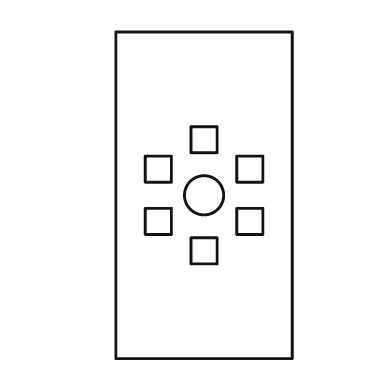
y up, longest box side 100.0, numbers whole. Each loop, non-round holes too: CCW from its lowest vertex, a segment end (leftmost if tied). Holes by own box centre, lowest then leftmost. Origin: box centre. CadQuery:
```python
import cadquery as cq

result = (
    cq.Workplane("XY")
    .moveTo(-27.0, -50.0)
    .lineTo(27.0, -50.0)
    .lineTo(27.0, 50.0)
    .lineTo(-27.0, 50.0)
    .close()
    .moveTo(-4.0, -21.0)
    .lineTo(4.0, -21.0)
    .lineTo(4.0, -13.0)
    .lineTo(-4.0, -13.0)
    .close()
    .moveTo(-18.0, -12.0)
    .lineTo(-10.0, -12.0)
    .lineTo(-10.0, -4.0)
    .lineTo(-18.0, -4.0)
    .close()
    .moveTo(10.0, -12.0)
    .lineTo(18.0, -12.0)
    .lineTo(18.0, -4.0)
    .lineTo(10.0, -4.0)
    .close()
    .moveTo(0.0, 0.0)
    .circle(6.0)
    .moveTo(-18.0, 4.0)
    .lineTo(-10.0, 4.0)
    .lineTo(-10.0, 12.0)
    .lineTo(-18.0, 12.0)
    .close()
    .moveTo(10.0, 4.0)
    .lineTo(18.0, 4.0)
    .lineTo(18.0, 12.0)
    .lineTo(10.0, 12.0)
    .close()
    .moveTo(-4.0, 13.0)
    .lineTo(4.0, 13.0)
    .lineTo(4.0, 21.0)
    .lineTo(-4.0, 21.0)
    .close()
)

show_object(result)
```